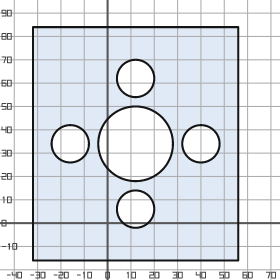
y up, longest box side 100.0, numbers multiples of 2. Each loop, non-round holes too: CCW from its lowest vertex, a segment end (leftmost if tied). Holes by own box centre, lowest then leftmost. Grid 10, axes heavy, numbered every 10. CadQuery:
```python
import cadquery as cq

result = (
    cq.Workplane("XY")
    .moveTo(-32.0, -16.0)
    .lineTo(56.0, -16.0)
    .lineTo(56.0, 84.0)
    .lineTo(-32.0, 84.0)
    .close()
    .moveTo(12.0, 6.0)
    .circle(8.0)
    .moveTo(-16.0, 34.0)
    .circle(8.0)
    .moveTo(12.0, 34.0)
    .circle(16.0)
    .moveTo(40.0, 34.0)
    .circle(8.0)
    .moveTo(12.0, 62.0)
    .circle(8.0)
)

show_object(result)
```